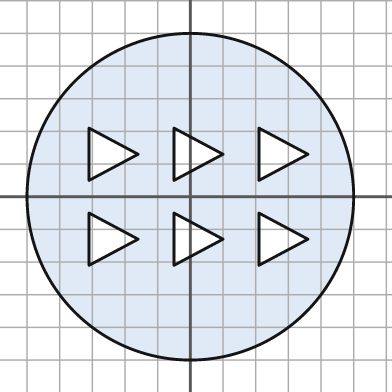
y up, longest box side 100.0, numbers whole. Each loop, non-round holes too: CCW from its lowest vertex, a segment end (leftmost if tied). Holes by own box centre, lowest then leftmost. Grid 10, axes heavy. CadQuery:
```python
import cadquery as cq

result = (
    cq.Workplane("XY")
    .moveTo(0.0, 0.0)
    .circle(50.0)
    .moveTo(-31.0, -21.0)
    .lineTo(-16.0, -13.0)
    .lineTo(-31.0, -5.0)
    .close()
    .moveTo(-5.0, -21.0)
    .lineTo(10.0, -13.0)
    .lineTo(-5.0, -5.0)
    .close()
    .moveTo(21.0, -21.0)
    .lineTo(36.0, -13.0)
    .lineTo(21.0, -5.0)
    .close()
    .moveTo(-31.0, 5.0)
    .lineTo(-16.0, 13.0)
    .lineTo(-31.0, 21.0)
    .close()
    .moveTo(-5.0, 5.0)
    .lineTo(10.0, 13.0)
    .lineTo(-5.0, 21.0)
    .close()
    .moveTo(21.0, 5.0)
    .lineTo(36.0, 13.0)
    .lineTo(21.0, 21.0)
    .close()
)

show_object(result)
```